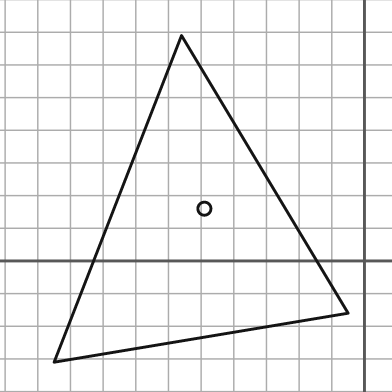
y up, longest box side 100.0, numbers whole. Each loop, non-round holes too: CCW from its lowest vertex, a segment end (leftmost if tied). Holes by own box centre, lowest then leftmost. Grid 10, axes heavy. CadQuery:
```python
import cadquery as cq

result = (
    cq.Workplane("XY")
    .moveTo(-95.0, -31.0)
    .lineTo(-5.0, -16.0)
    .lineTo(-56.0, 69.0)
    .close()
    .moveTo(-49.0, 16.0)
    .circle(2.0)
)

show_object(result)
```